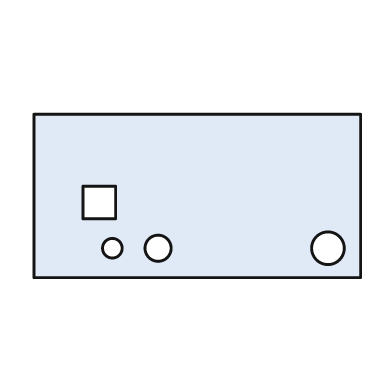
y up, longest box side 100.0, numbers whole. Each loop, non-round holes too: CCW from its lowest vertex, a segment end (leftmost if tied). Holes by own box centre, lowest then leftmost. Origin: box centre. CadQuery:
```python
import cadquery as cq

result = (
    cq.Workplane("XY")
    .moveTo(-50.0, -25.0)
    .lineTo(50.0, -25.0)
    .lineTo(50.0, 25.0)
    .lineTo(-50.0, 25.0)
    .close()
    .moveTo(-26.0, -16.0)
    .circle(3.0)
    .moveTo(-12.0, -16.0)
    .circle(4.0)
    .moveTo(40.0, -16.0)
    .circle(5.0)
    .moveTo(-35.0, -7.0)
    .lineTo(-25.0, -7.0)
    .lineTo(-25.0, 3.0)
    .lineTo(-35.0, 3.0)
    .close()
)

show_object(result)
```